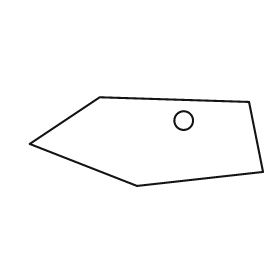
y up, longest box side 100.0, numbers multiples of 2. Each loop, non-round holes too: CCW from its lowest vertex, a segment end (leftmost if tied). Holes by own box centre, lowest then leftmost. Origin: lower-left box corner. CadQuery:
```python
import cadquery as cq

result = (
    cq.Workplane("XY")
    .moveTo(46.0, 0.0)
    .lineTo(100.0, 6.0)
    .lineTo(94.0, 36.0)
    .lineTo(30.0, 38.0)
    .lineTo(0.0, 18.0)
    .close()
    .moveTo(66.0, 28.0)
    .circle(4.0)
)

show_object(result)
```